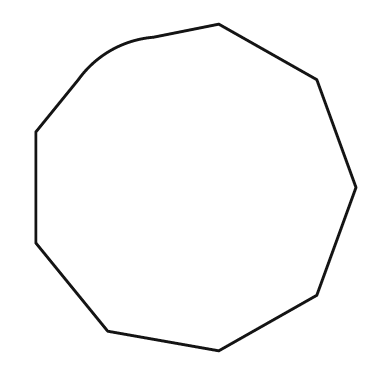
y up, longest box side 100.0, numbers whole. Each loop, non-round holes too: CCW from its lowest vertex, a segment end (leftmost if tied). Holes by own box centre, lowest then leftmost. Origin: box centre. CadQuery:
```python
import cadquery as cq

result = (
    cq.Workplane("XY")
    .moveTo(7.0, -50.0)
    .lineTo(37.0, -33.0)
    .lineTo(49.0, 0.0)
    .lineTo(37.0, 33.0)
    .lineTo(7.0, 50.0)
    .lineTo(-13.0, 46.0)
    .threePointArc((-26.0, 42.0), (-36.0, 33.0))
    .lineTo(-49.0, 17.0)
    .lineTo(-49.0, -17.0)
    .lineTo(-27.0, -44.0)
    .close()
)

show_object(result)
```